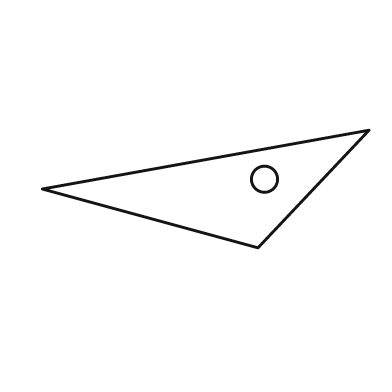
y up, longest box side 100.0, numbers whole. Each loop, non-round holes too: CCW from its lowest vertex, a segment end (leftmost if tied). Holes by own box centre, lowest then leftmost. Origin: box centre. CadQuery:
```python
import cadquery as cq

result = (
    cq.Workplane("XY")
    .moveTo(16.0, -18.0)
    .lineTo(50.0, 18.0)
    .lineTo(-50.0, 0.0)
    .close()
    .moveTo(18.0, 3.0)
    .circle(4.0)
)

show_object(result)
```